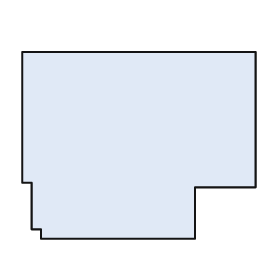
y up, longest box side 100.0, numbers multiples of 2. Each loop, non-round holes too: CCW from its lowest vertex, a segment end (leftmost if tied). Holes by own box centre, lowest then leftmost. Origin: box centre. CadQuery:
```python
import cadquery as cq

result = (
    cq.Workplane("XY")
    .moveTo(-42.0, -40.0)
    .lineTo(24.0, -40.0)
    .lineTo(24.0, -18.0)
    .lineTo(50.0, -18.0)
    .lineTo(50.0, 40.0)
    .lineTo(-50.0, 40.0)
    .lineTo(-50.0, -16.0)
    .lineTo(-46.0, -16.0)
    .lineTo(-46.0, -36.0)
    .lineTo(-42.0, -36.0)
    .close()
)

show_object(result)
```